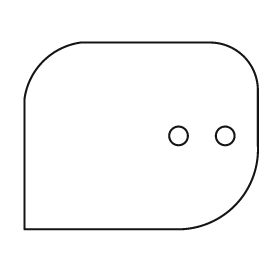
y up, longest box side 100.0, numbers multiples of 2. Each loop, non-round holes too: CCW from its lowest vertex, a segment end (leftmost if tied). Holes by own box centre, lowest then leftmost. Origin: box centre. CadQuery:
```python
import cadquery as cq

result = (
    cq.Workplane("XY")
    .moveTo(-50.0, -40.0)
    .lineTo(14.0, -40.0)
    .threePointArc((40.0, -30.0), (50.0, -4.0))
    .lineTo(50.0, 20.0)
    .threePointArc((44.0, 34.0), (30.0, 40.0))
    .lineTo(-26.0, 40.0)
    .threePointArc((-42.0, 32.0), (-50.0, 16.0))
    .close()
    .moveTo(16.0, 0.0)
    .circle(4.0)
    .moveTo(36.0, 0.0)
    .circle(4.0)
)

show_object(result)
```